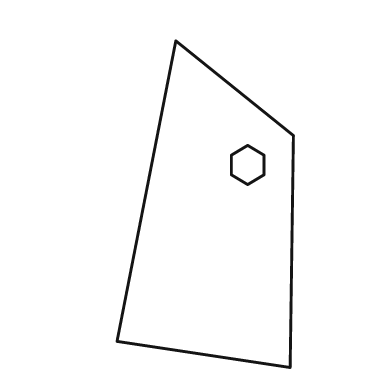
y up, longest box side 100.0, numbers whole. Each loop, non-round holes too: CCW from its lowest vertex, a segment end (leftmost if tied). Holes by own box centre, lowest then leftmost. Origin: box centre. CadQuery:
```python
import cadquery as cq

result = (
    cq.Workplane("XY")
    .moveTo(26.0, -50.0)
    .lineTo(27.0, 21.0)
    .lineTo(-9.0, 50.0)
    .lineTo(-27.0, -42.0)
    .close()
    .moveTo(13.0, 6.0)
    .lineTo(18.0, 9.0)
    .lineTo(18.0, 15.0)
    .lineTo(13.0, 18.0)
    .lineTo(8.0, 15.0)
    .lineTo(8.0, 9.0)
    .close()
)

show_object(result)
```